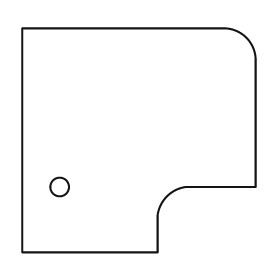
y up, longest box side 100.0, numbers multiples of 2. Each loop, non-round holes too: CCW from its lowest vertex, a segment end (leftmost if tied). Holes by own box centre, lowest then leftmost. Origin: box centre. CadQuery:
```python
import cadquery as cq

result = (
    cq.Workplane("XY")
    .moveTo(-50.0, -48.0)
    .lineTo(8.0, -48.0)
    .lineTo(8.0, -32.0)
    .threePointArc((12.0, -24.0), (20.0, -20.0))
    .lineTo(50.0, -20.0)
    .lineTo(50.0, 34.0)
    .threePointArc((46.0, 44.0), (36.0, 48.0))
    .lineTo(-50.0, 48.0)
    .close()
    .moveTo(-34.0, -20.0)
    .circle(4.0)
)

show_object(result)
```